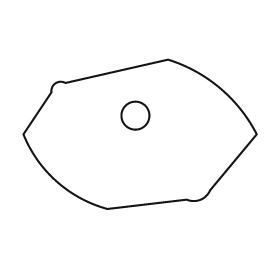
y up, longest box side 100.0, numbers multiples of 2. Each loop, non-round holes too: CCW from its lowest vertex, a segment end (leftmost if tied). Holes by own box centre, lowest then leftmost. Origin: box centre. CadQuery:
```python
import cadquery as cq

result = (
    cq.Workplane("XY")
    .moveTo(-14.0, -32.0)
    .lineTo(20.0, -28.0)
    .threePointArc((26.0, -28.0), (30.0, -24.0))
    .lineTo(50.0, 0.0)
    .threePointArc((34.0, 20.0), (12.0, 32.0))
    .lineTo(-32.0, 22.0)
    .threePointArc((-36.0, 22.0), (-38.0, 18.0))
    .lineTo(-50.0, 0.0)
    .threePointArc((-36.0, -20.0), (-14.0, -32.0))
    .close()
    .moveTo(-2.0, 8.0)
    .circle(6.0)
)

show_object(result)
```